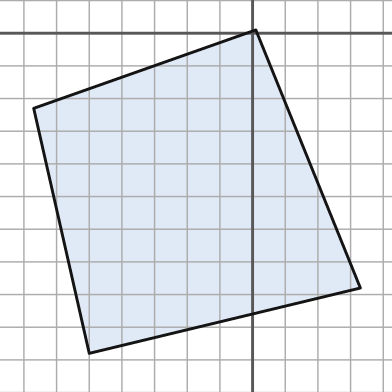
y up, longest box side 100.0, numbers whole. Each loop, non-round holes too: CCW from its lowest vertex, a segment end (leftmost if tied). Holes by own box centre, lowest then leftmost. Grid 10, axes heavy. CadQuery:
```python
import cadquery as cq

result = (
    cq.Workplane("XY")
    .moveTo(-50.0, -98.0)
    .lineTo(33.0, -78.0)
    .lineTo(1.0, 1.0)
    .lineTo(-67.0, -23.0)
    .close()
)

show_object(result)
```